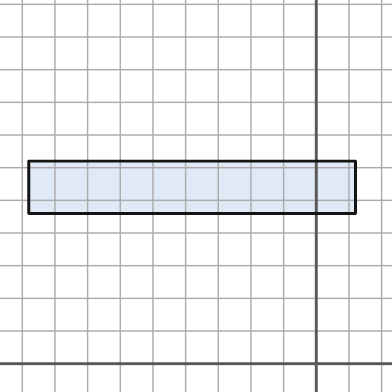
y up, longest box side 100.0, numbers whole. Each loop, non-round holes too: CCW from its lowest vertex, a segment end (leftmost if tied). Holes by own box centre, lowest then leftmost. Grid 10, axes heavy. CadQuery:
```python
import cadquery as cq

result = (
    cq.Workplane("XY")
    .moveTo(-88.0, 46.0)
    .lineTo(12.0, 46.0)
    .lineTo(12.0, 62.0)
    .lineTo(-88.0, 62.0)
    .close()
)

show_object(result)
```